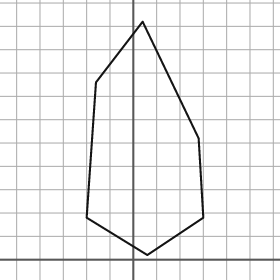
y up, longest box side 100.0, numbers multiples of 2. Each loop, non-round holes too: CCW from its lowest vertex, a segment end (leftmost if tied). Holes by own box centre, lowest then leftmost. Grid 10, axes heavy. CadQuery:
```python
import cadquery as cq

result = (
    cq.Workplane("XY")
    .moveTo(6.0, 2.0)
    .lineTo(30.0, 18.0)
    .lineTo(28.0, 52.0)
    .lineTo(4.0, 102.0)
    .lineTo(-16.0, 76.0)
    .lineTo(-20.0, 18.0)
    .close()
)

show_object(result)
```